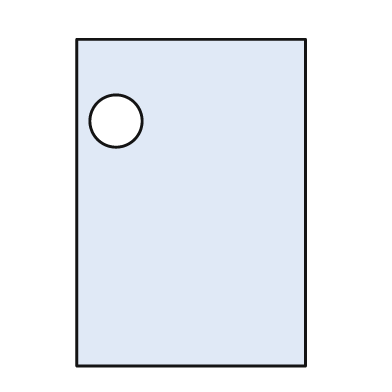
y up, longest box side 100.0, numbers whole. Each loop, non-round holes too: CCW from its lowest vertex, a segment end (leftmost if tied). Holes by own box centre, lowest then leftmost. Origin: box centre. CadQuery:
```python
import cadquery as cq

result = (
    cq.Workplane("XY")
    .moveTo(-35.0, -50.0)
    .lineTo(35.0, -50.0)
    .lineTo(35.0, 50.0)
    .lineTo(-35.0, 50.0)
    .close()
    .moveTo(-23.0, 25.0)
    .circle(8.0)
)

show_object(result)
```